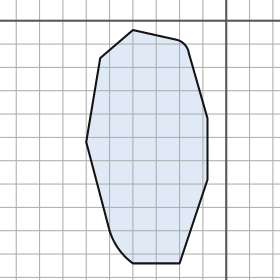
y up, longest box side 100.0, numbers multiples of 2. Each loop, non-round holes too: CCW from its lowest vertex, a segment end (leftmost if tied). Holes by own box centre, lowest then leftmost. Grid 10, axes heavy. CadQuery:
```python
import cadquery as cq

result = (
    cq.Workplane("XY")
    .moveTo(-40.0, -104.0)
    .lineTo(-20.0, -104.0)
    .lineTo(-8.0, -68.0)
    .lineTo(-8.0, -42.0)
    .lineTo(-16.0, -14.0)
    .threePointArc((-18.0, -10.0), (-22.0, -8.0))
    .lineTo(-40.0, -4.0)
    .lineTo(-54.0, -16.0)
    .lineTo(-60.0, -52.0)
    .lineTo(-50.0, -90.0)
    .threePointArc((-46.0, -98.0), (-40.0, -104.0))
    .close()
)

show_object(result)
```